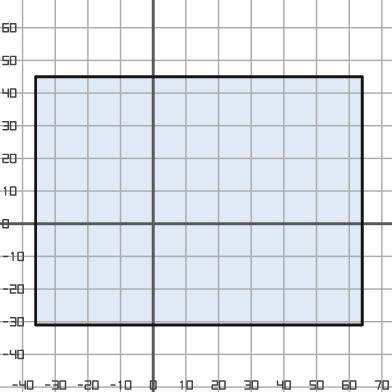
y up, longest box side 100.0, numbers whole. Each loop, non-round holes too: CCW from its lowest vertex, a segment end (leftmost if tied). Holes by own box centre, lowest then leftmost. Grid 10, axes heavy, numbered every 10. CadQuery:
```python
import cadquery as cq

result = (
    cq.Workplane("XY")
    .moveTo(-36.0, -31.0)
    .lineTo(64.0, -31.0)
    .lineTo(64.0, 45.0)
    .lineTo(-36.0, 45.0)
    .close()
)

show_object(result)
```